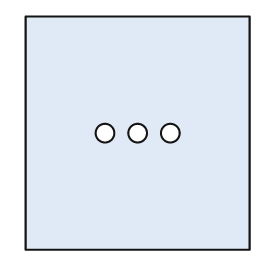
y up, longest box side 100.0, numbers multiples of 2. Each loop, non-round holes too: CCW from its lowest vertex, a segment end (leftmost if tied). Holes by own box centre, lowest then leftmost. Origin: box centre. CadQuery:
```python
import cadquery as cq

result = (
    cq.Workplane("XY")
    .moveTo(-48.0, -50.0)
    .lineTo(48.0, -50.0)
    .lineTo(48.0, 50.0)
    .lineTo(-48.0, 50.0)
    .close()
    .moveTo(-14.0, 0.0)
    .circle(4.0)
    .moveTo(0.0, 0.0)
    .circle(4.0)
    .moveTo(14.0, 0.0)
    .circle(4.0)
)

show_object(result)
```